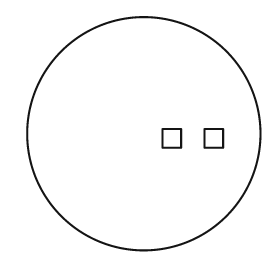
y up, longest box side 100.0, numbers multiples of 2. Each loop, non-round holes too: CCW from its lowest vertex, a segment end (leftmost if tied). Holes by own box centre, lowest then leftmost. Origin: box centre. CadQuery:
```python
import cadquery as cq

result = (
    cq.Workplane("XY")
    .moveTo(0.0, 0.0)
    .circle(50.0)
    .moveTo(8.0, -6.0)
    .lineTo(16.0, -6.0)
    .lineTo(16.0, 2.0)
    .lineTo(8.0, 2.0)
    .close()
    .moveTo(26.0, -6.0)
    .lineTo(34.0, -6.0)
    .lineTo(34.0, 2.0)
    .lineTo(26.0, 2.0)
    .close()
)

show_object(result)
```